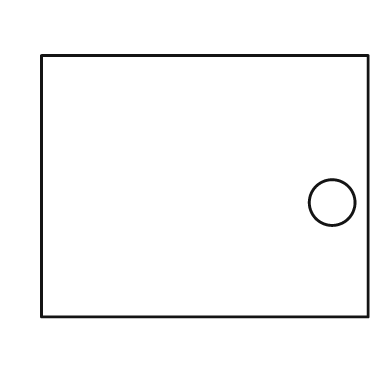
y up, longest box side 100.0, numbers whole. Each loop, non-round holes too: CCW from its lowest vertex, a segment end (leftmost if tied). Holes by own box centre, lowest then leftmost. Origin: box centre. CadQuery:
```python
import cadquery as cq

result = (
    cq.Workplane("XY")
    .moveTo(-50.0, -40.0)
    .lineTo(50.0, -40.0)
    .lineTo(50.0, 40.0)
    .lineTo(-50.0, 40.0)
    .close()
    .moveTo(39.0, -5.0)
    .circle(7.0)
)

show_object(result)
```